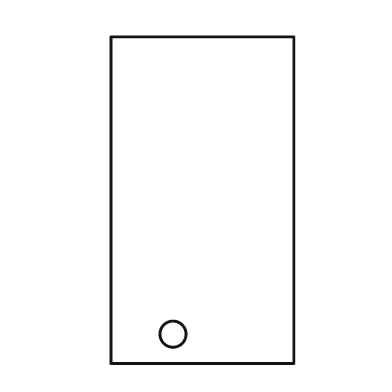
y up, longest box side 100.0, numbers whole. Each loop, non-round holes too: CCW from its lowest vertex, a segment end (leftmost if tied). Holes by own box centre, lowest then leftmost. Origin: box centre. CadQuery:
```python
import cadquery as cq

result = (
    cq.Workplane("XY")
    .moveTo(-28.0, -50.0)
    .lineTo(28.0, -50.0)
    .lineTo(28.0, 50.0)
    .lineTo(-28.0, 50.0)
    .close()
    .moveTo(-9.0, -41.0)
    .circle(4.0)
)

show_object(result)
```